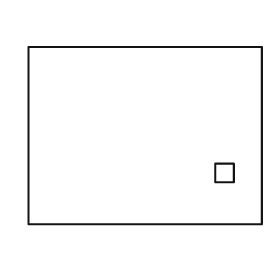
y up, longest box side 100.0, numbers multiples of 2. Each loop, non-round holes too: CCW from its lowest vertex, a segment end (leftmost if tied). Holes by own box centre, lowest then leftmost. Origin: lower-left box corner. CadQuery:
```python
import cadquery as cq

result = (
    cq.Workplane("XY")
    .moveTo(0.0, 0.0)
    .lineTo(100.0, 0.0)
    .lineTo(100.0, 76.0)
    .lineTo(0.0, 76.0)
    .close()
    .moveTo(80.0, 18.0)
    .lineTo(88.0, 18.0)
    .lineTo(88.0, 26.0)
    .lineTo(80.0, 26.0)
    .close()
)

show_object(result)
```